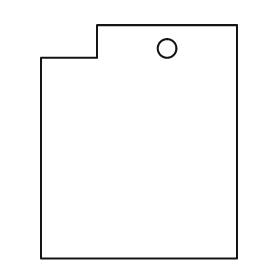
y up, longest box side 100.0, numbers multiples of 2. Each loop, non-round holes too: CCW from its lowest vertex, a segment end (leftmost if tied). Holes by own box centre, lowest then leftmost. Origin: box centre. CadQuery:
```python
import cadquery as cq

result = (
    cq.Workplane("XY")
    .moveTo(-42.0, -50.0)
    .lineTo(42.0, -50.0)
    .lineTo(42.0, 50.0)
    .lineTo(-18.0, 50.0)
    .lineTo(-18.0, 36.0)
    .lineTo(-42.0, 36.0)
    .close()
    .moveTo(12.0, 40.0)
    .circle(4.0)
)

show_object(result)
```